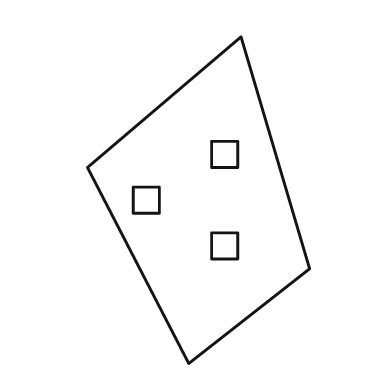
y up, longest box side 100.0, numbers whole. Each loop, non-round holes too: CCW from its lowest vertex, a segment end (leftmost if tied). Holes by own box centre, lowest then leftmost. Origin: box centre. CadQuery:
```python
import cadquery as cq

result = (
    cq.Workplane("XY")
    .moveTo(-3.0, -50.0)
    .lineTo(34.0, -21.0)
    .lineTo(13.0, 50.0)
    .lineTo(-34.0, 10.0)
    .close()
    .moveTo(4.0, -18.0)
    .lineTo(12.0, -18.0)
    .lineTo(12.0, -10.0)
    .lineTo(4.0, -10.0)
    .close()
    .moveTo(-20.0, -4.0)
    .lineTo(-12.0, -4.0)
    .lineTo(-12.0, 4.0)
    .lineTo(-20.0, 4.0)
    .close()
    .moveTo(4.0, 10.0)
    .lineTo(12.0, 10.0)
    .lineTo(12.0, 18.0)
    .lineTo(4.0, 18.0)
    .close()
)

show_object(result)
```